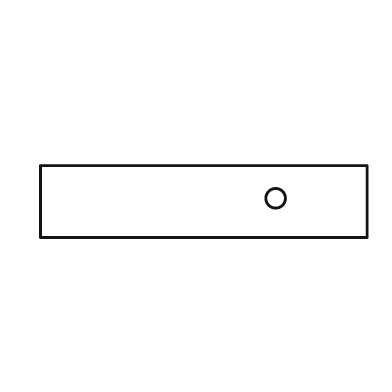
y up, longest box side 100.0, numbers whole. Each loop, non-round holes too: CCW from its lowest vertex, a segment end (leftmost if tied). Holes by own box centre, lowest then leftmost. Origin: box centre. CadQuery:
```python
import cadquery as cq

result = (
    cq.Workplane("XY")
    .moveTo(-50.0, -11.0)
    .lineTo(50.0, -11.0)
    .lineTo(50.0, 11.0)
    .lineTo(-50.0, 11.0)
    .close()
    .moveTo(22.0, 1.0)
    .circle(3.0)
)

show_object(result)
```